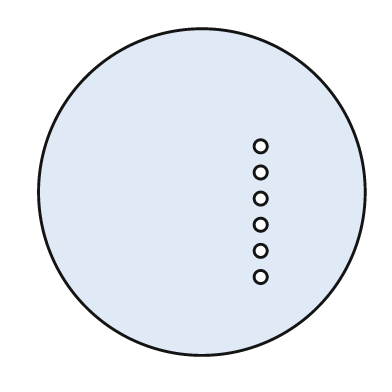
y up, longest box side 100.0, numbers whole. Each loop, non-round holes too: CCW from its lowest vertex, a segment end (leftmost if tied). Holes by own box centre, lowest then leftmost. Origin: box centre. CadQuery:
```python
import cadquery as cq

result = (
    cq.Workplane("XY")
    .moveTo(0.0, 0.0)
    .circle(50.0)
    .moveTo(18.0, -26.0)
    .circle(2.0)
    .moveTo(18.0, -18.0)
    .circle(2.0)
    .moveTo(18.0, -10.0)
    .circle(2.0)
    .moveTo(18.0, -2.0)
    .circle(2.0)
    .moveTo(18.0, 6.0)
    .circle(2.0)
    .moveTo(18.0, 14.0)
    .circle(2.0)
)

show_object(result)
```